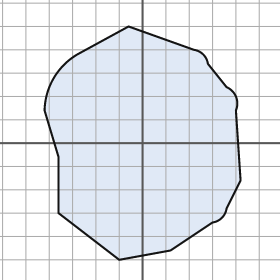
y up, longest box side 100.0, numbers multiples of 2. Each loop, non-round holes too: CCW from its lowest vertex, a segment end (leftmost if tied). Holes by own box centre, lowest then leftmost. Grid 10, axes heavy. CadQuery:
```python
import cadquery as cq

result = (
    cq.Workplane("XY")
    .moveTo(-10.0, -50.0)
    .lineTo(12.0, -46.0)
    .lineTo(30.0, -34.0)
    .threePointArc((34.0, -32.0), (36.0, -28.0))
    .lineTo(42.0, -16.0)
    .lineTo(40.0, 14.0)
    .threePointArc((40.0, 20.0), (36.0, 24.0))
    .lineTo(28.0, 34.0)
    .threePointArc((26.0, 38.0), (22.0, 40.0))
    .lineTo(-6.0, 50.0)
    .lineTo(-28.0, 38.0)
    .threePointArc((-38.0, 28.0), (-42.0, 14.0))
    .lineTo(-36.0, -6.0)
    .lineTo(-36.0, -30.0)
    .close()
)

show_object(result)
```